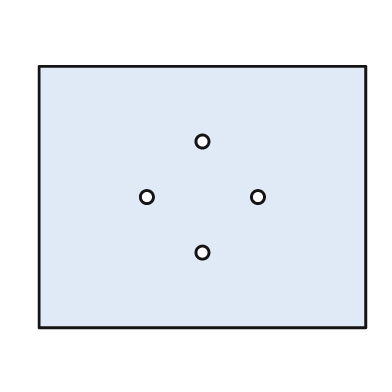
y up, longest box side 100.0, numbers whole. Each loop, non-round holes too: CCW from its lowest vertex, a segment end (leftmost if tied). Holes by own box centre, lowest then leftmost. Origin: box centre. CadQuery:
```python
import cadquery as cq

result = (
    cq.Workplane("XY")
    .moveTo(-50.0, -40.0)
    .lineTo(50.0, -40.0)
    .lineTo(50.0, 40.0)
    .lineTo(-50.0, 40.0)
    .close()
    .moveTo(0.0, -17.0)
    .circle(2.0)
    .moveTo(-17.0, 0.0)
    .circle(2.0)
    .moveTo(17.0, 0.0)
    .circle(2.0)
    .moveTo(0.0, 17.0)
    .circle(2.0)
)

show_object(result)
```